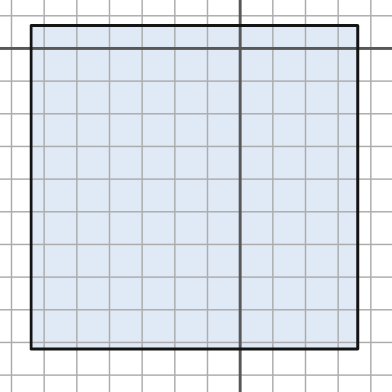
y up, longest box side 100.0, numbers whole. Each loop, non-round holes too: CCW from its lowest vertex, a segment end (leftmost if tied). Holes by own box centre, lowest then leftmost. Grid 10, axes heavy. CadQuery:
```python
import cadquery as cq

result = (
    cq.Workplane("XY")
    .moveTo(-64.0, -92.0)
    .lineTo(36.0, -92.0)
    .lineTo(36.0, 7.0)
    .lineTo(-64.0, 7.0)
    .close()
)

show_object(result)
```